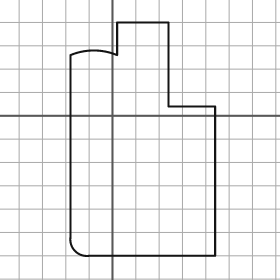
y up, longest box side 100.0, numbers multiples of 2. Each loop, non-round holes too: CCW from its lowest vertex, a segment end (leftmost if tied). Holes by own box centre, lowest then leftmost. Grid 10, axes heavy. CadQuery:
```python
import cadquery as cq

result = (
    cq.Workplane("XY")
    .moveTo(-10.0, -60.0)
    .lineTo(44.0, -60.0)
    .lineTo(44.0, 4.0)
    .lineTo(24.0, 4.0)
    .lineTo(24.0, 40.0)
    .lineTo(2.0, 40.0)
    .lineTo(2.0, 26.0)
    .threePointArc((-8.0, 28.0), (-18.0, 26.0))
    .lineTo(-18.0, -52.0)
    .threePointArc((-16.0, -58.0), (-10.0, -60.0))
    .close()
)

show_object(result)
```